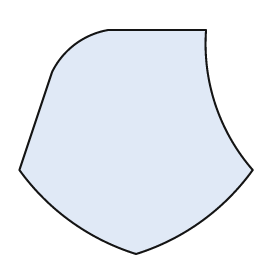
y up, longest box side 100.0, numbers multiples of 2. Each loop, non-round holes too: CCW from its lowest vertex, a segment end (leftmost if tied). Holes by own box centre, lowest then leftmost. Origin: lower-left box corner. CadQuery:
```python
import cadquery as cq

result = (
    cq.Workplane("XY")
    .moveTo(50.0, 0.0)
    .threePointArc((78.0, 14.0), (100.0, 36.0))
    .threePointArc((84.0, 64.0), (80.0, 96.0))
    .lineTo(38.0, 96.0)
    .threePointArc((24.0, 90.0), (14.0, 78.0))
    .lineTo(0.0, 36.0)
    .threePointArc((22.0, 14.0), (50.0, 0.0))
    .close()
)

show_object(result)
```